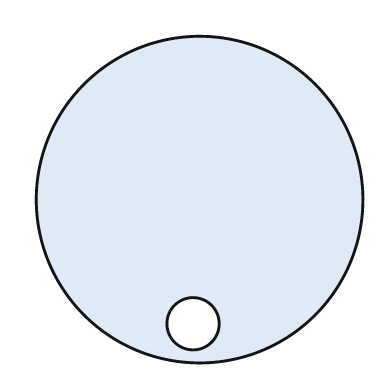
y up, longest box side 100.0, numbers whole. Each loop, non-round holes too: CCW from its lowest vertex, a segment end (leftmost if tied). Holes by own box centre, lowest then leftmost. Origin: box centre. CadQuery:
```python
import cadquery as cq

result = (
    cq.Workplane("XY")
    .moveTo(0.0, 0.0)
    .circle(50.0)
    .moveTo(-2.0, -38.0)
    .circle(8.0)
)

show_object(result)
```